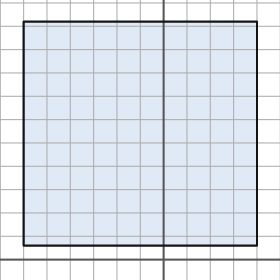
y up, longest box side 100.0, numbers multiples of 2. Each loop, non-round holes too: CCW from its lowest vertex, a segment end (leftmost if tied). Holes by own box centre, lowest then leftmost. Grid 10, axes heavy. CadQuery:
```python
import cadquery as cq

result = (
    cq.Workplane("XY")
    .moveTo(-60.0, 6.0)
    .lineTo(40.0, 6.0)
    .lineTo(40.0, 102.0)
    .lineTo(-60.0, 102.0)
    .close()
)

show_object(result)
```